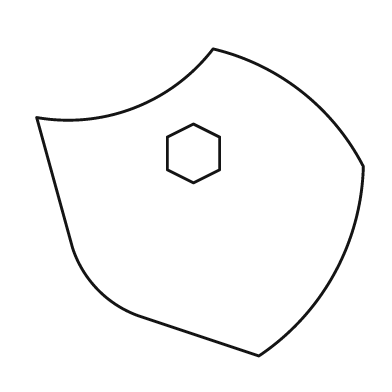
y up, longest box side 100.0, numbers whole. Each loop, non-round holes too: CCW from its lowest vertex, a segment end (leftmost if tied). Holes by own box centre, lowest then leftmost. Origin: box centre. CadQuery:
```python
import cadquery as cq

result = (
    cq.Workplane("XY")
    .moveTo(18.0, -47.0)
    .threePointArc((41.0, -22.0), (50.0, 11.0))
    .threePointArc((31.0, 34.0), (4.0, 47.0))
    .threePointArc((-20.0, 29.0), (-50.0, 26.0))
    .lineTo(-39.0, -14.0)
    .threePointArc((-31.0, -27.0), (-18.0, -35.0))
    .close()
    .moveTo(-2.0, 6.0)
    .lineTo(6.0, 10.0)
    .lineTo(6.0, 20.0)
    .lineTo(-2.0, 24.0)
    .lineTo(-10.0, 20.0)
    .lineTo(-10.0, 10.0)
    .close()
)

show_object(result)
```